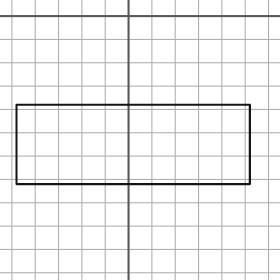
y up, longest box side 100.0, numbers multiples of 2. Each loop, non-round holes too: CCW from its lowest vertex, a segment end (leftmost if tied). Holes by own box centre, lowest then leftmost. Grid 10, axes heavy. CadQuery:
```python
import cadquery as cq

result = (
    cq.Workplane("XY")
    .moveTo(-48.0, -72.0)
    .lineTo(52.0, -72.0)
    .lineTo(52.0, -38.0)
    .lineTo(-48.0, -38.0)
    .close()
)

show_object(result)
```